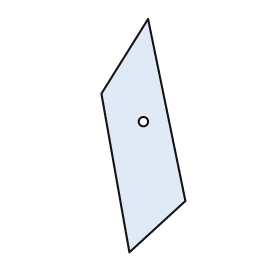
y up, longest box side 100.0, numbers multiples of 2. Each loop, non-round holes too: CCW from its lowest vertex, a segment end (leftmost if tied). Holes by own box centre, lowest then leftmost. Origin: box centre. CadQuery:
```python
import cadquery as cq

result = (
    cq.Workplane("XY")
    .moveTo(-6.0, -50.0)
    .lineTo(18.0, -28.0)
    .lineTo(2.0, 50.0)
    .lineTo(-18.0, 18.0)
    .close()
    .moveTo(0.0, 6.0)
    .circle(2.0)
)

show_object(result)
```